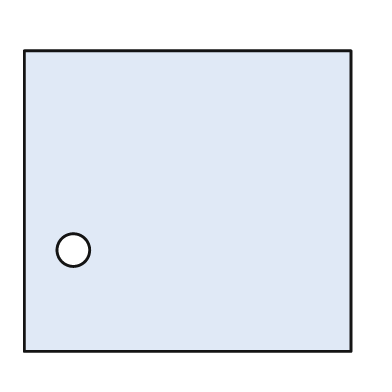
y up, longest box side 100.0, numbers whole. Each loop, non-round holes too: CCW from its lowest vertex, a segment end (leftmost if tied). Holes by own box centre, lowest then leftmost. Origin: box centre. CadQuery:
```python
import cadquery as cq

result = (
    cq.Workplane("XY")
    .moveTo(-50.0, -46.0)
    .lineTo(50.0, -46.0)
    .lineTo(50.0, 46.0)
    .lineTo(-50.0, 46.0)
    .close()
    .moveTo(-35.0, -15.0)
    .circle(5.0)
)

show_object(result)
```